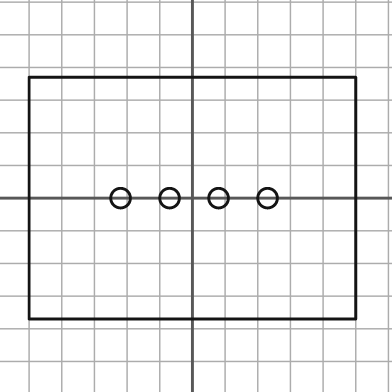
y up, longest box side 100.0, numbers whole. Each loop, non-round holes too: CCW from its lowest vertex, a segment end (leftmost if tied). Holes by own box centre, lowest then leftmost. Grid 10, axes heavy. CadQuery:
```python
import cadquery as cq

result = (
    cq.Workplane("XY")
    .moveTo(-50.0, -37.0)
    .lineTo(50.0, -37.0)
    .lineTo(50.0, 37.0)
    .lineTo(-50.0, 37.0)
    .close()
    .moveTo(-22.0, 0.0)
    .circle(3.0)
    .moveTo(-7.0, 0.0)
    .circle(3.0)
    .moveTo(8.0, 0.0)
    .circle(3.0)
    .moveTo(23.0, 0.0)
    .circle(3.0)
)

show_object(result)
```